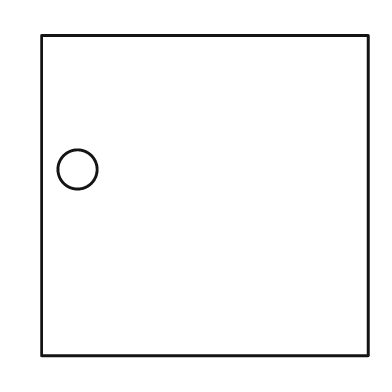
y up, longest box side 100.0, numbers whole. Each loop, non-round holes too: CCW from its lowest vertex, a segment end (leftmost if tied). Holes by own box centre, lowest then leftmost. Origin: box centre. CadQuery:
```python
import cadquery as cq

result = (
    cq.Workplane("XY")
    .moveTo(-50.0, -49.0)
    .lineTo(50.0, -49.0)
    .lineTo(50.0, 49.0)
    .lineTo(-50.0, 49.0)
    .close()
    .moveTo(-39.0, 8.0)
    .circle(6.0)
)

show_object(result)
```